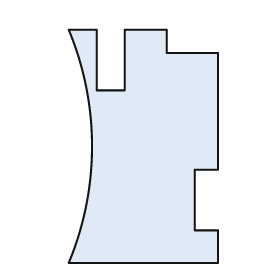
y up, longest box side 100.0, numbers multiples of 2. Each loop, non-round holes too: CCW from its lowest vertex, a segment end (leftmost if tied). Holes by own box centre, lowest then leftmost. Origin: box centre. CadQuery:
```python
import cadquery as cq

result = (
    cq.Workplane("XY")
    .moveTo(-32.0, -50.0)
    .lineTo(32.0, -50.0)
    .lineTo(32.0, -36.0)
    .lineTo(22.0, -36.0)
    .lineTo(22.0, -10.0)
    .lineTo(32.0, -10.0)
    .lineTo(32.0, 40.0)
    .lineTo(10.0, 40.0)
    .lineTo(10.0, 50.0)
    .lineTo(-8.0, 50.0)
    .lineTo(-8.0, 24.0)
    .lineTo(-20.0, 24.0)
    .lineTo(-20.0, 50.0)
    .lineTo(-32.0, 50.0)
    .threePointArc((-22.0, 0.0), (-32.0, -50.0))
    .close()
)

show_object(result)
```